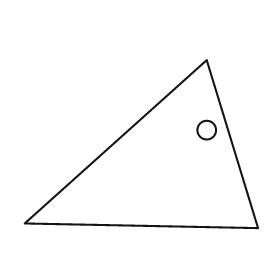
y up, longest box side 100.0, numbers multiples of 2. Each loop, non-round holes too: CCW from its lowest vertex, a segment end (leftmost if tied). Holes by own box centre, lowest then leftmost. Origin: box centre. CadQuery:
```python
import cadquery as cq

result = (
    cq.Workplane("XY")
    .moveTo(50.0, -36.0)
    .lineTo(28.0, 36.0)
    .lineTo(-50.0, -34.0)
    .close()
    .moveTo(28.0, 6.0)
    .circle(4.0)
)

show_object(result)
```